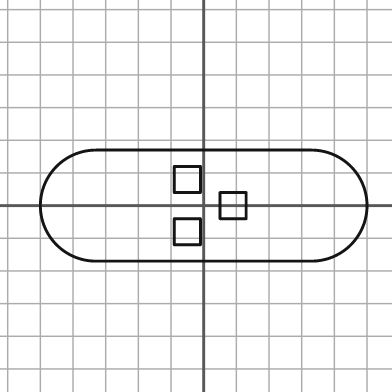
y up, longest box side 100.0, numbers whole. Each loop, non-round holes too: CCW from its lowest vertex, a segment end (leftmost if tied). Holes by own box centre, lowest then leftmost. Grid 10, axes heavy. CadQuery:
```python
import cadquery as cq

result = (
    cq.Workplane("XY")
    .moveTo(-33.0, -17.0)
    .lineTo(33.0, -17.0)
    .threePointArc((50.0, 0.0), (33.0, 17.0))
    .lineTo(-33.0, 17.0)
    .threePointArc((-50.0, 0.0), (-33.0, -17.0))
    .close()
    .moveTo(-9.0, -12.0)
    .lineTo(-1.0, -12.0)
    .lineTo(-1.0, -4.0)
    .lineTo(-9.0, -4.0)
    .close()
    .moveTo(5.0, -4.0)
    .lineTo(13.0, -4.0)
    .lineTo(13.0, 4.0)
    .lineTo(5.0, 4.0)
    .close()
    .moveTo(-9.0, 4.0)
    .lineTo(-1.0, 4.0)
    .lineTo(-1.0, 12.0)
    .lineTo(-9.0, 12.0)
    .close()
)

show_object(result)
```